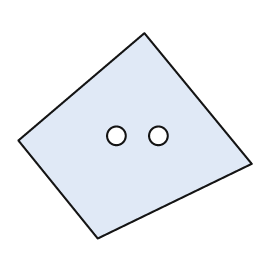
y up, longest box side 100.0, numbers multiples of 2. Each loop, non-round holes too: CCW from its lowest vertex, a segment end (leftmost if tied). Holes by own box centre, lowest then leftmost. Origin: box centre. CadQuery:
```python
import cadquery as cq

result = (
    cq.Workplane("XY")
    .moveTo(-16.0, -44.0)
    .lineTo(50.0, -12.0)
    .lineTo(4.0, 44.0)
    .lineTo(-50.0, -2.0)
    .close()
    .moveTo(-8.0, 0.0)
    .circle(4.0)
    .moveTo(10.0, 0.0)
    .circle(4.0)
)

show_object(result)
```